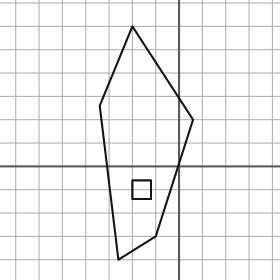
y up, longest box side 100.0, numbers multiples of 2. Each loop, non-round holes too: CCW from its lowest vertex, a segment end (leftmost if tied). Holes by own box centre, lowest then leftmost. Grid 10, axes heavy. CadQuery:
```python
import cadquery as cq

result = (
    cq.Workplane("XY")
    .moveTo(-26.0, -40.0)
    .lineTo(-10.0, -30.0)
    .lineTo(6.0, 20.0)
    .lineTo(-20.0, 60.0)
    .lineTo(-34.0, 26.0)
    .close()
    .moveTo(-20.0, -14.0)
    .lineTo(-12.0, -14.0)
    .lineTo(-12.0, -6.0)
    .lineTo(-20.0, -6.0)
    .close()
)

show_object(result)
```